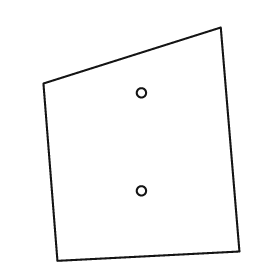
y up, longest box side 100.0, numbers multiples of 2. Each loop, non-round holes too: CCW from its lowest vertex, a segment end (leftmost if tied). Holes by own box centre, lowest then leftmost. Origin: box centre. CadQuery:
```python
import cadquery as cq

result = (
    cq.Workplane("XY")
    .moveTo(-36.0, -50.0)
    .lineTo(42.0, -46.0)
    .lineTo(34.0, 50.0)
    .lineTo(-42.0, 26.0)
    .close()
    .moveTo(0.0, -20.0)
    .circle(2.0)
    .moveTo(0.0, 22.0)
    .circle(2.0)
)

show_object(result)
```